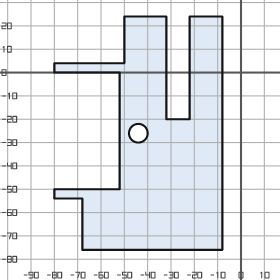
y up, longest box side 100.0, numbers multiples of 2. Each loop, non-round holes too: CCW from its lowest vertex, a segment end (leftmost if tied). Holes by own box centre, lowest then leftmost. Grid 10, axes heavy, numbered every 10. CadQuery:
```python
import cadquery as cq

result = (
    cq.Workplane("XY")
    .moveTo(-68.0, -76.0)
    .lineTo(-8.0, -76.0)
    .lineTo(-8.0, 24.0)
    .lineTo(-22.0, 24.0)
    .lineTo(-22.0, -20.0)
    .lineTo(-32.0, -20.0)
    .lineTo(-32.0, 24.0)
    .lineTo(-50.0, 24.0)
    .lineTo(-50.0, 4.0)
    .lineTo(-80.0, 4.0)
    .lineTo(-80.0, 0.0)
    .lineTo(-52.0, 0.0)
    .lineTo(-52.0, -50.0)
    .lineTo(-80.0, -50.0)
    .lineTo(-80.0, -54.0)
    .lineTo(-68.0, -54.0)
    .close()
    .moveTo(-44.0, -26.0)
    .circle(4.0)
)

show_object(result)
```